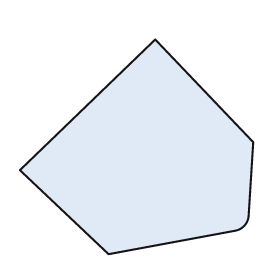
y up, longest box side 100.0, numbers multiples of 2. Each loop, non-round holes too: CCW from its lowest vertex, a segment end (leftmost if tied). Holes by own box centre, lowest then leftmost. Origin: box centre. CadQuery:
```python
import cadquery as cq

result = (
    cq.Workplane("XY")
    .moveTo(-12.0, -46.0)
    .lineTo(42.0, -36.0)
    .threePointArc((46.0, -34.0), (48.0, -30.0))
    .lineTo(50.0, 2.0)
    .lineTo(8.0, 46.0)
    .lineTo(-50.0, -10.0)
    .close()
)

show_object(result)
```